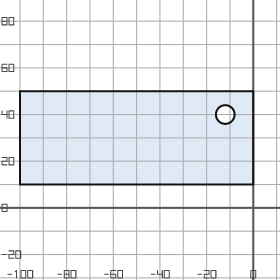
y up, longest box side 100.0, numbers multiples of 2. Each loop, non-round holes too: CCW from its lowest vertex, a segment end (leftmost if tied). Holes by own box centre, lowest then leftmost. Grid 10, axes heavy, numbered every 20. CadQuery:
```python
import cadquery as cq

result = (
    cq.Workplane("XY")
    .moveTo(-100.0, 10.0)
    .lineTo(0.0, 10.0)
    .lineTo(0.0, 50.0)
    .lineTo(-100.0, 50.0)
    .close()
    .moveTo(-12.0, 40.0)
    .circle(4.0)
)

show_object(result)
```